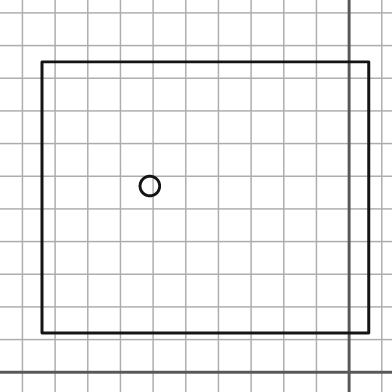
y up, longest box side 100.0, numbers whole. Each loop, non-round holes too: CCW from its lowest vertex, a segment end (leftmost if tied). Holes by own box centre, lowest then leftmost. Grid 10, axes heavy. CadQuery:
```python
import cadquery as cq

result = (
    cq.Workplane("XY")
    .moveTo(-94.0, 12.0)
    .lineTo(6.0, 12.0)
    .lineTo(6.0, 95.0)
    .lineTo(-94.0, 95.0)
    .close()
    .moveTo(-61.0, 57.0)
    .circle(3.0)
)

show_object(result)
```